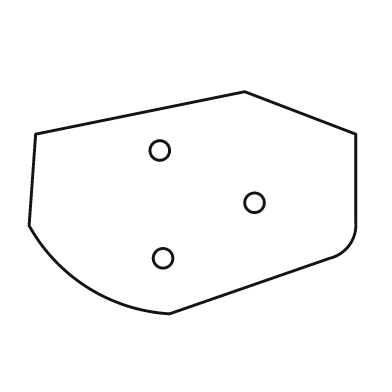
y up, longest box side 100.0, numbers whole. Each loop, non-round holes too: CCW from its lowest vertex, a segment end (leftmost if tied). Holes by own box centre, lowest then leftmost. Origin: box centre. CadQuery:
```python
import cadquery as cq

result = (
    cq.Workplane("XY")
    .moveTo(-7.0, -34.0)
    .lineTo(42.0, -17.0)
    .threePointArc((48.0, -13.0), (50.0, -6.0))
    .lineTo(50.0, 21.0)
    .lineTo(16.0, 34.0)
    .lineTo(-48.0, 21.0)
    .lineTo(-50.0, -7.0)
    .threePointArc((-32.0, -26.0), (-7.0, -34.0))
    .close()
    .moveTo(-9.0, -17.0)
    .circle(3.0)
    .moveTo(19.0, 0.0)
    .circle(3.0)
    .moveTo(-10.0, 16.0)
    .circle(3.0)
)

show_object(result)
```